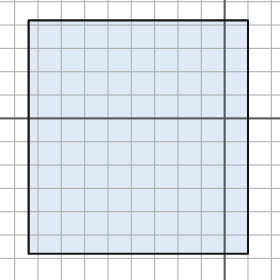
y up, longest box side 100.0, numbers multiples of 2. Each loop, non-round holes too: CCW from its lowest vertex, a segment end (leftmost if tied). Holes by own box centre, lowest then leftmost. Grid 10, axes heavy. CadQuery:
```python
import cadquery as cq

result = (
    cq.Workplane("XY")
    .moveTo(-84.0, -58.0)
    .lineTo(10.0, -58.0)
    .lineTo(10.0, 42.0)
    .lineTo(-84.0, 42.0)
    .close()
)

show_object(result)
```